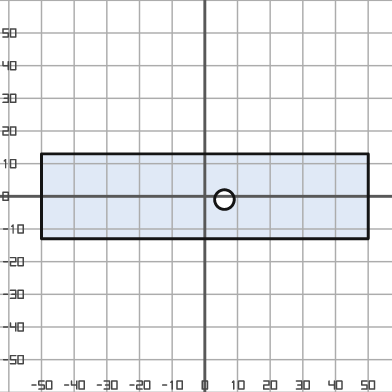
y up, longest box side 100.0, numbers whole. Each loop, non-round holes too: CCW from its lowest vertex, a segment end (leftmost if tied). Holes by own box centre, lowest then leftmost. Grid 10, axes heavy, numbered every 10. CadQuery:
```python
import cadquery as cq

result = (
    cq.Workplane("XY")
    .moveTo(-50.0, -13.0)
    .lineTo(50.0, -13.0)
    .lineTo(50.0, 13.0)
    .lineTo(-50.0, 13.0)
    .close()
    .moveTo(6.0, -1.0)
    .circle(3.0)
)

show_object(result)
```